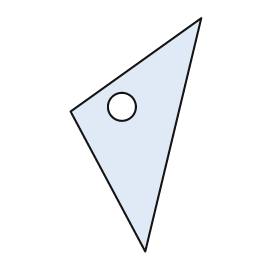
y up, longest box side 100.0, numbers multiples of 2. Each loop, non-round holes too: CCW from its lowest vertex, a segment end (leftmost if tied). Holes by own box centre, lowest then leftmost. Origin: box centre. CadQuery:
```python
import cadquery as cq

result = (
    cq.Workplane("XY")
    .moveTo(4.0, -50.0)
    .lineTo(28.0, 50.0)
    .lineTo(-28.0, 10.0)
    .close()
    .moveTo(-6.0, 12.0)
    .circle(6.0)
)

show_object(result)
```